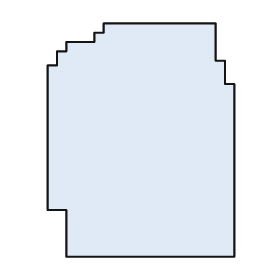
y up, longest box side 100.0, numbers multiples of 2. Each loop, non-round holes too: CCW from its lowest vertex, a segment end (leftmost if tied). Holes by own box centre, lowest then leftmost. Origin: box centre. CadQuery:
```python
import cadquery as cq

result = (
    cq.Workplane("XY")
    .moveTo(-32.0, -50.0)
    .lineTo(40.0, -50.0)
    .lineTo(40.0, 24.0)
    .lineTo(36.0, 24.0)
    .lineTo(36.0, 34.0)
    .lineTo(32.0, 34.0)
    .lineTo(32.0, 50.0)
    .lineTo(-16.0, 50.0)
    .lineTo(-16.0, 46.0)
    .lineTo(-20.0, 46.0)
    .lineTo(-20.0, 42.0)
    .lineTo(-32.0, 42.0)
    .lineTo(-32.0, 38.0)
    .lineTo(-36.0, 38.0)
    .lineTo(-36.0, 32.0)
    .lineTo(-40.0, 32.0)
    .lineTo(-40.0, -30.0)
    .lineTo(-32.0, -30.0)
    .close()
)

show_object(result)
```